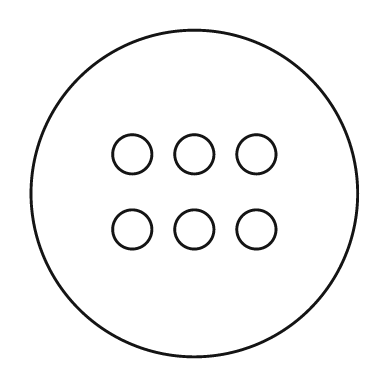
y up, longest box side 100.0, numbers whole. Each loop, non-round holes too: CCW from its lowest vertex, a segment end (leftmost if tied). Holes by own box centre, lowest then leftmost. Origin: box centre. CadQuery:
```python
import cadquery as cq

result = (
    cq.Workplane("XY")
    .moveTo(0.0, 0.0)
    .circle(50.0)
    .moveTo(-19.0, -11.0)
    .circle(6.0)
    .moveTo(0.0, -11.0)
    .circle(6.0)
    .moveTo(19.0, -11.0)
    .circle(6.0)
    .moveTo(-19.0, 12.0)
    .circle(6.0)
    .moveTo(0.0, 12.0)
    .circle(6.0)
    .moveTo(19.0, 12.0)
    .circle(6.0)
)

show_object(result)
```